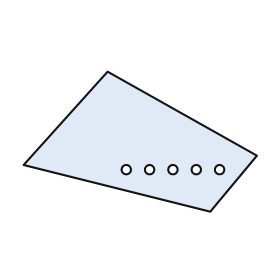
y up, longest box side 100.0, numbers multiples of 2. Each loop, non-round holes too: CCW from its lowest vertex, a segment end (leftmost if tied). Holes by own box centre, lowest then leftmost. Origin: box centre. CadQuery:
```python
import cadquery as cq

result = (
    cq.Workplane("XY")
    .moveTo(30.0, -30.0)
    .lineTo(50.0, -6.0)
    .lineTo(-14.0, 30.0)
    .lineTo(-50.0, -10.0)
    .close()
    .moveTo(-6.0, -12.0)
    .circle(2.0)
    .moveTo(4.0, -12.0)
    .circle(2.0)
    .moveTo(14.0, -12.0)
    .circle(2.0)
    .moveTo(24.0, -12.0)
    .circle(2.0)
    .moveTo(34.0, -12.0)
    .circle(2.0)
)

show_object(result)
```